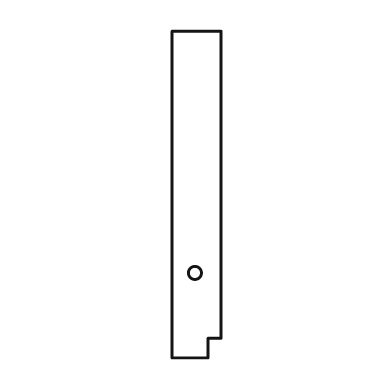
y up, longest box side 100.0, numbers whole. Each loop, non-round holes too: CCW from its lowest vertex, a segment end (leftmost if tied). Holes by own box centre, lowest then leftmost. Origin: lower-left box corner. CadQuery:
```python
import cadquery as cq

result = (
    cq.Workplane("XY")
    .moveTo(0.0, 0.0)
    .lineTo(11.0, 0.0)
    .lineTo(11.0, 6.0)
    .lineTo(15.0, 6.0)
    .lineTo(15.0, 100.0)
    .lineTo(0.0, 100.0)
    .close()
    .moveTo(7.0, 26.0)
    .circle(2.0)
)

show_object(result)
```